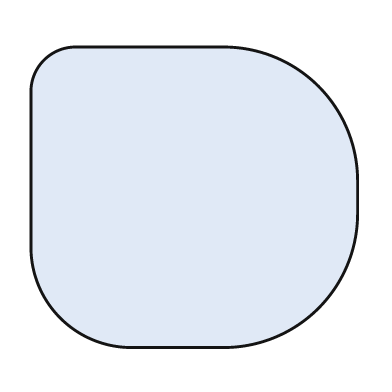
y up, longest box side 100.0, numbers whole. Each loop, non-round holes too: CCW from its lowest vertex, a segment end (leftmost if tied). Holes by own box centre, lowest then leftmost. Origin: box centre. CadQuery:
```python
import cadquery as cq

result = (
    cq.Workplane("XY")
    .moveTo(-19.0, -46.0)
    .lineTo(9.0, -46.0)
    .threePointArc((38.0, -34.0), (50.0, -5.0))
    .lineTo(50.0, 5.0)
    .threePointArc((38.0, 34.0), (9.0, 46.0))
    .lineTo(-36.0, 46.0)
    .threePointArc((-46.0, 42.0), (-50.0, 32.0))
    .lineTo(-50.0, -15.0)
    .threePointArc((-41.0, -37.0), (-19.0, -46.0))
    .close()
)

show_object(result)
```